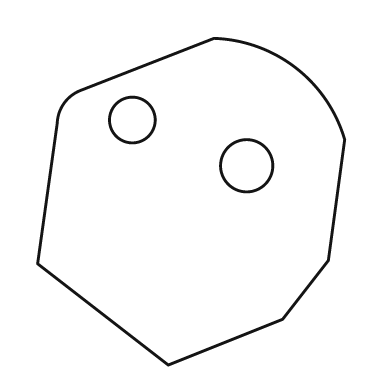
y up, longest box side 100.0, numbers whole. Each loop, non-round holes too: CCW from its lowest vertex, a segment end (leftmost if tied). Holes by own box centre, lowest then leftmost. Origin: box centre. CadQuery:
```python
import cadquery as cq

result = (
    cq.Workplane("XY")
    .moveTo(-7.0, -50.0)
    .lineTo(28.0, -36.0)
    .lineTo(42.0, -18.0)
    .lineTo(47.0, 19.0)
    .threePointArc((32.0, 41.0), (7.0, 50.0))
    .lineTo(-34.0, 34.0)
    .threePointArc((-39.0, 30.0), (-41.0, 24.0))
    .lineTo(-47.0, -19.0)
    .close()
    .moveTo(17.0, 11.0)
    .circle(8.0)
    .moveTo(-18.0, 25.0)
    .circle(7.0)
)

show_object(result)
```